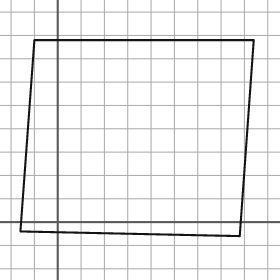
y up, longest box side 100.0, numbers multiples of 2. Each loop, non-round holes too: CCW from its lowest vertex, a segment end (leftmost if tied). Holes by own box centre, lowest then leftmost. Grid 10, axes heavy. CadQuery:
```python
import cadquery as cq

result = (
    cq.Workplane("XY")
    .moveTo(78.0, -6.0)
    .lineTo(84.0, 78.0)
    .lineTo(-10.0, 78.0)
    .lineTo(-16.0, -4.0)
    .close()
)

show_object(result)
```